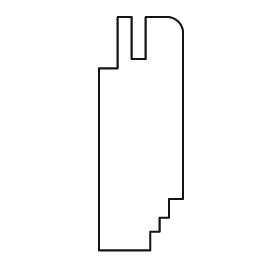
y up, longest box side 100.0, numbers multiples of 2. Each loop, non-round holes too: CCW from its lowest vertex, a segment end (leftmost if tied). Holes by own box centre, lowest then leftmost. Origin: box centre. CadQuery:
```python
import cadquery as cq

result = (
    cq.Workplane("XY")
    .moveTo(-18.0, -50.0)
    .lineTo(4.0, -50.0)
    .lineTo(4.0, -42.0)
    .lineTo(8.0, -42.0)
    .lineTo(8.0, -36.0)
    .lineTo(12.0, -36.0)
    .lineTo(12.0, -28.0)
    .lineTo(18.0, -28.0)
    .lineTo(18.0, 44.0)
    .threePointArc((16.0, 48.0), (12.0, 50.0))
    .lineTo(2.0, 50.0)
    .lineTo(2.0, 32.0)
    .lineTo(-4.0, 32.0)
    .lineTo(-4.0, 50.0)
    .lineTo(-10.0, 50.0)
    .lineTo(-10.0, 28.0)
    .lineTo(-18.0, 28.0)
    .close()
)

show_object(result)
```